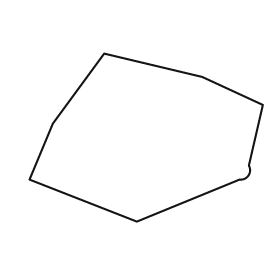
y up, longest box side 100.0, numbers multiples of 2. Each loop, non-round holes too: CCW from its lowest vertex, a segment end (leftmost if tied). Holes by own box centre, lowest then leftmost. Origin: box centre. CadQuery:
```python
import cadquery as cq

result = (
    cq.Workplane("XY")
    .moveTo(-4.0, -36.0)
    .lineTo(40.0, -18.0)
    .threePointArc((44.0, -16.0), (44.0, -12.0))
    .lineTo(50.0, 14.0)
    .lineTo(24.0, 26.0)
    .lineTo(-18.0, 36.0)
    .lineTo(-40.0, 6.0)
    .lineTo(-50.0, -18.0)
    .close()
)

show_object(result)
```